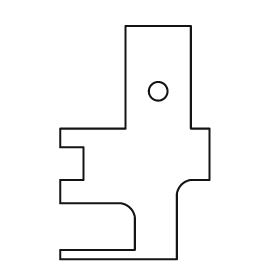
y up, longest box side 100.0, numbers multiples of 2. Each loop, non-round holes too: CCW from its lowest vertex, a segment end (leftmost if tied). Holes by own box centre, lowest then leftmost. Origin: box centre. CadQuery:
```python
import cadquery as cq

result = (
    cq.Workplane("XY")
    .moveTo(-32.0, -50.0)
    .lineTo(18.0, -50.0)
    .lineTo(18.0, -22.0)
    .threePointArc((20.0, -18.0), (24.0, -16.0))
    .lineTo(32.0, -16.0)
    .lineTo(32.0, 6.0)
    .lineTo(24.0, 6.0)
    .lineTo(24.0, 50.0)
    .lineTo(-4.0, 50.0)
    .lineTo(-4.0, 6.0)
    .lineTo(-32.0, 6.0)
    .lineTo(-32.0, -2.0)
    .lineTo(-22.0, -2.0)
    .lineTo(-22.0, -16.0)
    .lineTo(-32.0, -16.0)
    .lineTo(-32.0, -26.0)
    .lineTo(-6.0, -26.0)
    .threePointArc((-2.0, -28.0), (0.0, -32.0))
    .lineTo(0.0, -46.0)
    .lineTo(-32.0, -46.0)
    .close()
    .moveTo(10.0, 22.0)
    .circle(4.0)
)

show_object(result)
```